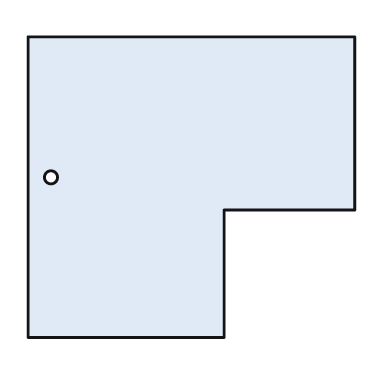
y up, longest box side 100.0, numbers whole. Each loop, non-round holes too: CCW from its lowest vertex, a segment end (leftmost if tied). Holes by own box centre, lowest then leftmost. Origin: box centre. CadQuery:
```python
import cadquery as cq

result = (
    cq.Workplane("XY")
    .moveTo(-50.0, -46.0)
    .lineTo(10.0, -46.0)
    .lineTo(10.0, -7.0)
    .lineTo(50.0, -7.0)
    .lineTo(50.0, 46.0)
    .lineTo(-50.0, 46.0)
    .close()
    .moveTo(-43.0, 3.0)
    .circle(2.0)
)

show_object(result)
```